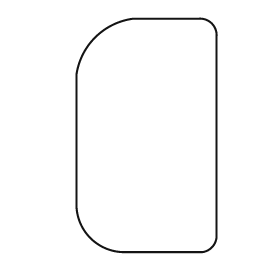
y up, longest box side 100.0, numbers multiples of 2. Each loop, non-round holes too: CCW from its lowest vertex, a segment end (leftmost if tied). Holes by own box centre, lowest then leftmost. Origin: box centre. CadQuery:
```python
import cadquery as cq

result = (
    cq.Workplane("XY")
    .moveTo(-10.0, -50.0)
    .lineTo(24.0, -50.0)
    .threePointArc((28.0, -48.0), (30.0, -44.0))
    .lineTo(30.0, 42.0)
    .threePointArc((28.0, 48.0), (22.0, 50.0))
    .lineTo(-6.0, 50.0)
    .threePointArc((-22.0, 42.0), (-30.0, 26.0))
    .lineTo(-30.0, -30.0)
    .threePointArc((-24.0, -44.0), (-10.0, -50.0))
    .close()
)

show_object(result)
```